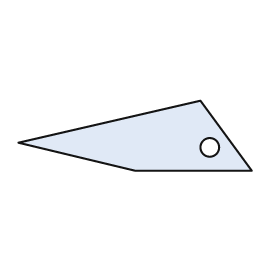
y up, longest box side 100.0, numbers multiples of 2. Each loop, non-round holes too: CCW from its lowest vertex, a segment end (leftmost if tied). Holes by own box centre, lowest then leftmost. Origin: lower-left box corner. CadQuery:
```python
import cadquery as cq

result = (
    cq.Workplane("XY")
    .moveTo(50.0, 0.0)
    .lineTo(100.0, 0.0)
    .lineTo(78.0, 30.0)
    .lineTo(0.0, 12.0)
    .close()
    .moveTo(82.0, 10.0)
    .circle(4.0)
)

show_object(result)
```